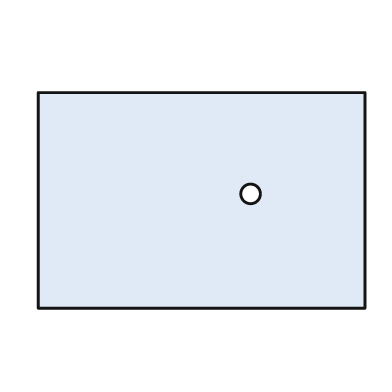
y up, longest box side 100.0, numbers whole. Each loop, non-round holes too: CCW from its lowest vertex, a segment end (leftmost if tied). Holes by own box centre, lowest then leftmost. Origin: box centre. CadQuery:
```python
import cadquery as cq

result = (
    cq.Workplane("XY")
    .moveTo(-50.0, -33.0)
    .lineTo(50.0, -33.0)
    .lineTo(50.0, 33.0)
    .lineTo(-50.0, 33.0)
    .close()
    .moveTo(15.0, 2.0)
    .circle(3.0)
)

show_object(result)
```